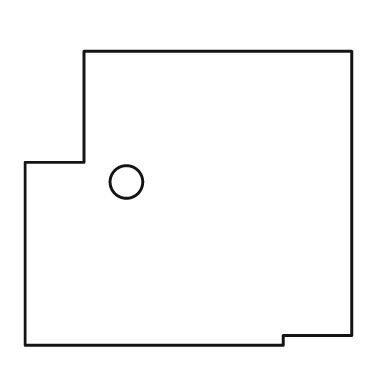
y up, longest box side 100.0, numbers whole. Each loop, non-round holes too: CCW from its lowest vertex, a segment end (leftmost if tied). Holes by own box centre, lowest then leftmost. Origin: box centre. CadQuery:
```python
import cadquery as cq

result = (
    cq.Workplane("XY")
    .moveTo(-50.0, -45.0)
    .lineTo(29.0, -45.0)
    .lineTo(29.0, -42.0)
    .lineTo(50.0, -42.0)
    .lineTo(50.0, 45.0)
    .lineTo(-32.0, 45.0)
    .lineTo(-32.0, 11.0)
    .lineTo(-50.0, 11.0)
    .close()
    .moveTo(-19.0, 5.0)
    .circle(5.0)
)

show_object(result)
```